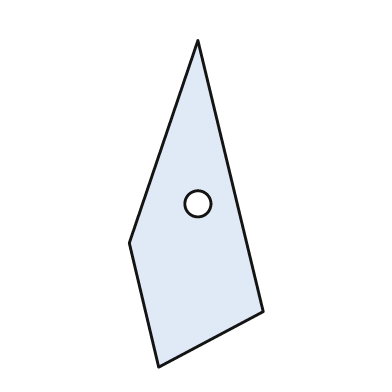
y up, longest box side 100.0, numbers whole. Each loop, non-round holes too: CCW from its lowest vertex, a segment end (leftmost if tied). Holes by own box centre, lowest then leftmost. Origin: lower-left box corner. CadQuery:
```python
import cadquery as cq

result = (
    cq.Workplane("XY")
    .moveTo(9.0, 0.0)
    .lineTo(41.0, 17.0)
    .lineTo(21.0, 100.0)
    .lineTo(0.0, 38.0)
    .close()
    .moveTo(21.0, 50.0)
    .circle(4.0)
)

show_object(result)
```